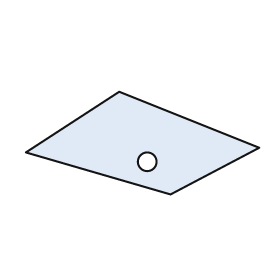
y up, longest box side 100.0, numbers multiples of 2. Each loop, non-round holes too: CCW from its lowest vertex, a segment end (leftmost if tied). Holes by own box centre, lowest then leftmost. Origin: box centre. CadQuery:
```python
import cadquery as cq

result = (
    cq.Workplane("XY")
    .moveTo(12.0, -22.0)
    .lineTo(50.0, -2.0)
    .lineTo(-10.0, 22.0)
    .lineTo(-50.0, -4.0)
    .close()
    .moveTo(2.0, -8.0)
    .circle(4.0)
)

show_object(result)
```